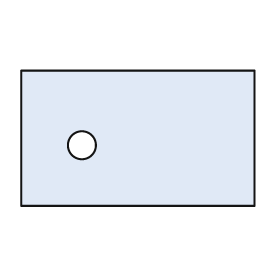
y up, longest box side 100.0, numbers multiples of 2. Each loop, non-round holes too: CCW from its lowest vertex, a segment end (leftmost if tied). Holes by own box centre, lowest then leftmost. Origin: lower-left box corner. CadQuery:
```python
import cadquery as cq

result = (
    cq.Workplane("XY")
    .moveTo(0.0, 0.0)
    .lineTo(100.0, 0.0)
    .lineTo(100.0, 58.0)
    .lineTo(0.0, 58.0)
    .close()
    .moveTo(26.0, 26.0)
    .circle(6.0)
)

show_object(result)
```